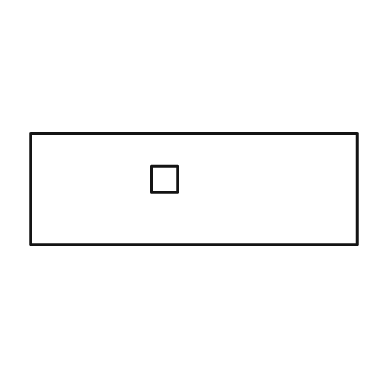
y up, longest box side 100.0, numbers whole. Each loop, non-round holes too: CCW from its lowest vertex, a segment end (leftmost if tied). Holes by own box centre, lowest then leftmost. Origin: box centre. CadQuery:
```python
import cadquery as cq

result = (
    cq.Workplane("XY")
    .moveTo(-50.0, -17.0)
    .lineTo(50.0, -17.0)
    .lineTo(50.0, 17.0)
    .lineTo(-50.0, 17.0)
    .close()
    .moveTo(-13.0, -1.0)
    .lineTo(-5.0, -1.0)
    .lineTo(-5.0, 7.0)
    .lineTo(-13.0, 7.0)
    .close()
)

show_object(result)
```